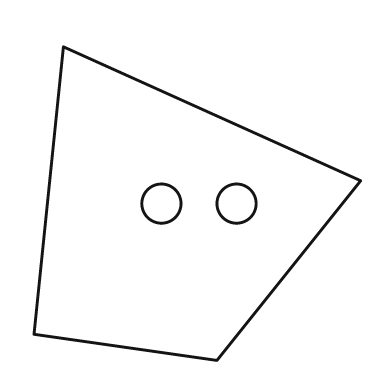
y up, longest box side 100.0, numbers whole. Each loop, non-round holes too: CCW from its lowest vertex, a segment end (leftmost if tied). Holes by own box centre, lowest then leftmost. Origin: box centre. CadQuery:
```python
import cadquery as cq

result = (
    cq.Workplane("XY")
    .moveTo(6.0, -48.0)
    .lineTo(50.0, 7.0)
    .lineTo(-41.0, 48.0)
    .lineTo(-50.0, -40.0)
    .close()
    .moveTo(-11.0, 0.0)
    .circle(6.0)
    .moveTo(12.0, 0.0)
    .circle(6.0)
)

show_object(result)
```